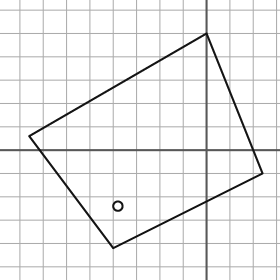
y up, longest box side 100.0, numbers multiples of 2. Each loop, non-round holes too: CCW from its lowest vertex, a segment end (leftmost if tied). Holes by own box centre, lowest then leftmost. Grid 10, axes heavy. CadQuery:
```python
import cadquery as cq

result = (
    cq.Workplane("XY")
    .moveTo(-40.0, -42.0)
    .lineTo(24.0, -10.0)
    .lineTo(0.0, 50.0)
    .lineTo(-76.0, 6.0)
    .close()
    .moveTo(-38.0, -24.0)
    .circle(2.0)
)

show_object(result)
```